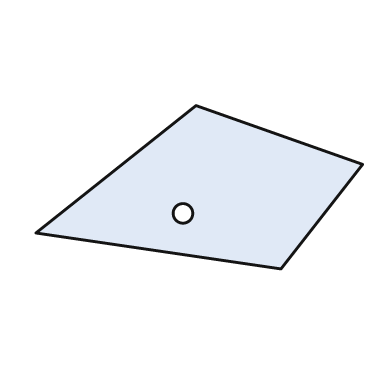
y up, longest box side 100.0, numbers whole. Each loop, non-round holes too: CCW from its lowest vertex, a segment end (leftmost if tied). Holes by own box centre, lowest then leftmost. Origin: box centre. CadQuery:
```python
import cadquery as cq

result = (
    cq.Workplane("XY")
    .moveTo(25.0, -25.0)
    .lineTo(50.0, 7.0)
    .lineTo(-1.0, 25.0)
    .lineTo(-50.0, -14.0)
    .close()
    .moveTo(-5.0, -8.0)
    .circle(3.0)
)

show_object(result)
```